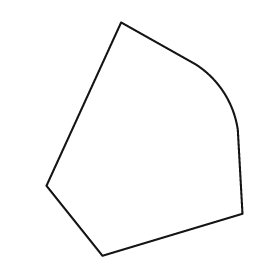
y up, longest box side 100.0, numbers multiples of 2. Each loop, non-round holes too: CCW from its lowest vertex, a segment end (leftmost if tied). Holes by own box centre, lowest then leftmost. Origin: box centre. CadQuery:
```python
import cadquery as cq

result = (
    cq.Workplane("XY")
    .moveTo(-18.0, -50.0)
    .lineTo(42.0, -32.0)
    .lineTo(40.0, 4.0)
    .threePointArc((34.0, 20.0), (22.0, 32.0))
    .lineTo(-10.0, 50.0)
    .lineTo(-42.0, -20.0)
    .close()
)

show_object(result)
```